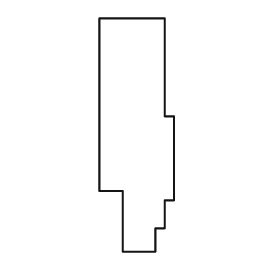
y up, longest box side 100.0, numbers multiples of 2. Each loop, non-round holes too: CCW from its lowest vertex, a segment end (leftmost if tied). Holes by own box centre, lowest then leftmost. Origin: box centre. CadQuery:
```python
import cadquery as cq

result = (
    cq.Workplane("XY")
    .moveTo(-6.0, -50.0)
    .lineTo(8.0, -50.0)
    .lineTo(8.0, -40.0)
    .lineTo(12.0, -40.0)
    .lineTo(12.0, -28.0)
    .lineTo(16.0, -28.0)
    .lineTo(16.0, 8.0)
    .lineTo(12.0, 8.0)
    .lineTo(12.0, 50.0)
    .lineTo(-16.0, 50.0)
    .lineTo(-16.0, -24.0)
    .lineTo(-6.0, -24.0)
    .close()
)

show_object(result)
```